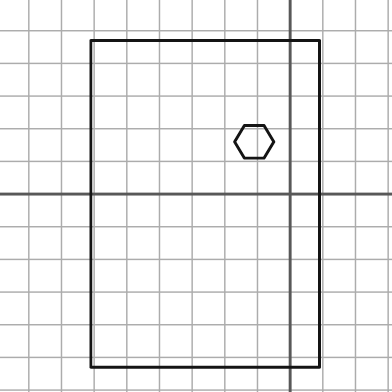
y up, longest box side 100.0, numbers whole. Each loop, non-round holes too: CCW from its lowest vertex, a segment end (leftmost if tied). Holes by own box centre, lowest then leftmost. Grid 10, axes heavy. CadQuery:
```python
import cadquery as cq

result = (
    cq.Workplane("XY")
    .moveTo(-61.0, -53.0)
    .lineTo(9.0, -53.0)
    .lineTo(9.0, 47.0)
    .lineTo(-61.0, 47.0)
    .close()
    .moveTo(-14.0, 11.0)
    .lineTo(-8.0, 11.0)
    .lineTo(-5.0, 16.0)
    .lineTo(-8.0, 21.0)
    .lineTo(-14.0, 21.0)
    .lineTo(-17.0, 16.0)
    .close()
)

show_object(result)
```